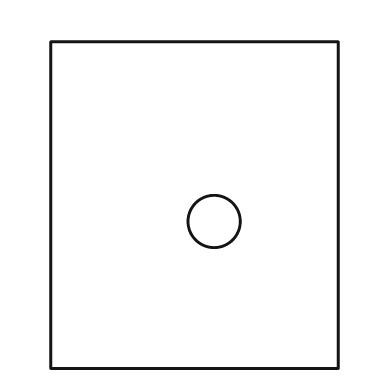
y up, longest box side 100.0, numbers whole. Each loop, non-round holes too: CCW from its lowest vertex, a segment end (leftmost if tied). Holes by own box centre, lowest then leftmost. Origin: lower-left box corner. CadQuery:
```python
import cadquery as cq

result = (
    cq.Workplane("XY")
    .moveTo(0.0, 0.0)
    .lineTo(88.0, 0.0)
    .lineTo(88.0, 100.0)
    .lineTo(0.0, 100.0)
    .close()
    .moveTo(50.0, 45.0)
    .circle(8.0)
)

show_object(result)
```